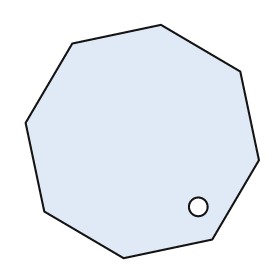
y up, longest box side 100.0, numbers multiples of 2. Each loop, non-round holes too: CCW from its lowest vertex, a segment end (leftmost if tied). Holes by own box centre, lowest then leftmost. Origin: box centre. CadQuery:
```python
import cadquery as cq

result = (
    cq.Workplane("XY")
    .moveTo(-8.0, -50.0)
    .lineTo(30.0, -42.0)
    .lineTo(50.0, -8.0)
    .lineTo(42.0, 30.0)
    .lineTo(8.0, 50.0)
    .lineTo(-30.0, 42.0)
    .lineTo(-50.0, 8.0)
    .lineTo(-42.0, -30.0)
    .close()
    .moveTo(24.0, -28.0)
    .circle(4.0)
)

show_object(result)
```